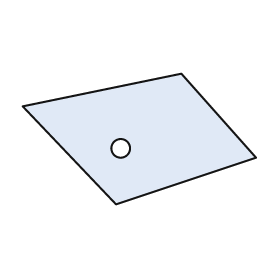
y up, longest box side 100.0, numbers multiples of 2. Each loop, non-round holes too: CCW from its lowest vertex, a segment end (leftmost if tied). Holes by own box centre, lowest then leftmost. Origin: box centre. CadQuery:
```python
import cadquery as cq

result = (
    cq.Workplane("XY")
    .moveTo(-10.0, -28.0)
    .lineTo(50.0, -8.0)
    .lineTo(18.0, 28.0)
    .lineTo(-50.0, 14.0)
    .close()
    .moveTo(-8.0, -4.0)
    .circle(4.0)
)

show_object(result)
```